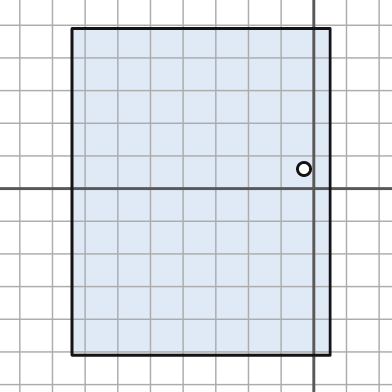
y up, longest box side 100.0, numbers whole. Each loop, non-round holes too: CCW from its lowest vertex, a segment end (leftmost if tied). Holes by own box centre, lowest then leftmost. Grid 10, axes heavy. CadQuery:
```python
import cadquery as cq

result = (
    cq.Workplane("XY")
    .moveTo(-74.0, -51.0)
    .lineTo(5.0, -51.0)
    .lineTo(5.0, 49.0)
    .lineTo(-74.0, 49.0)
    .close()
    .moveTo(-3.0, 6.0)
    .circle(2.0)
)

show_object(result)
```